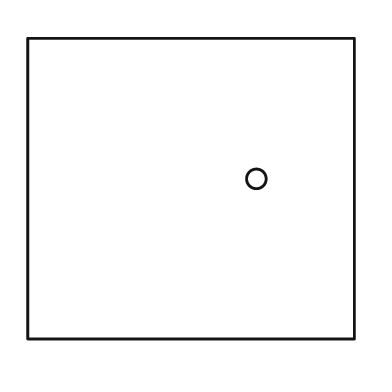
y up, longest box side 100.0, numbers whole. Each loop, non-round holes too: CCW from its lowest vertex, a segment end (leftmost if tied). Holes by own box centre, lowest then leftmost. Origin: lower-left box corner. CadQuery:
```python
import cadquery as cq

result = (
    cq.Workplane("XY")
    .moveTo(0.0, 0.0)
    .lineTo(100.0, 0.0)
    .lineTo(100.0, 92.0)
    .lineTo(0.0, 92.0)
    .close()
    .moveTo(70.0, 49.0)
    .circle(3.0)
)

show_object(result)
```